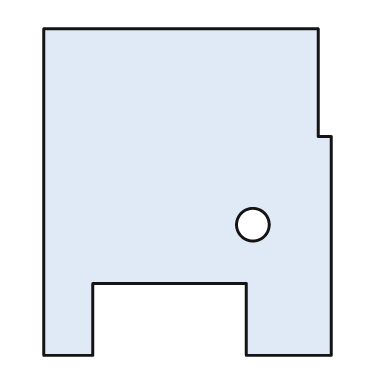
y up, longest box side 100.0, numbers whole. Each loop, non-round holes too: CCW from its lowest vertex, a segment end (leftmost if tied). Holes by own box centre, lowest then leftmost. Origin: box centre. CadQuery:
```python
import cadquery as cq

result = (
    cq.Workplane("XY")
    .moveTo(-44.0, -50.0)
    .lineTo(-29.0, -50.0)
    .lineTo(-29.0, -28.0)
    .lineTo(18.0, -28.0)
    .lineTo(18.0, -50.0)
    .lineTo(44.0, -50.0)
    .lineTo(44.0, 17.0)
    .lineTo(40.0, 17.0)
    .lineTo(40.0, 50.0)
    .lineTo(-44.0, 50.0)
    .close()
    .moveTo(20.0, -10.0)
    .circle(5.0)
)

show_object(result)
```